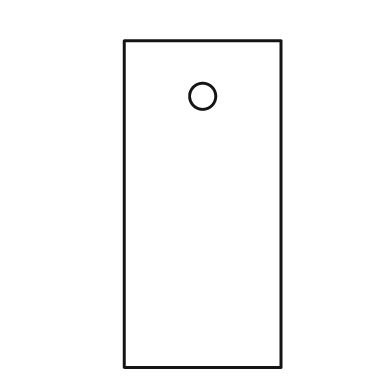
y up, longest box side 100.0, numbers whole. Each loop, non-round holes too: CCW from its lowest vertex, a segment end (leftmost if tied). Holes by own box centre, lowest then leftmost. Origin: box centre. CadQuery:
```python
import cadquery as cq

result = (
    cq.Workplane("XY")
    .moveTo(-24.0, -50.0)
    .lineTo(24.0, -50.0)
    .lineTo(24.0, 50.0)
    .lineTo(-24.0, 50.0)
    .close()
    .moveTo(0.0, 33.0)
    .circle(4.0)
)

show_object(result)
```